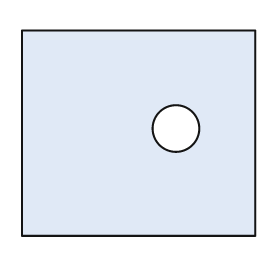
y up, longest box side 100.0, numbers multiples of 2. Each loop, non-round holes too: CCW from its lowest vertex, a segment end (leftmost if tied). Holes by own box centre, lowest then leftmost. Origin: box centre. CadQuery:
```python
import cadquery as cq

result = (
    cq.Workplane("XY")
    .moveTo(-50.0, -44.0)
    .lineTo(50.0, -44.0)
    .lineTo(50.0, 44.0)
    .lineTo(-50.0, 44.0)
    .close()
    .moveTo(16.0, 2.0)
    .circle(10.0)
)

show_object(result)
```